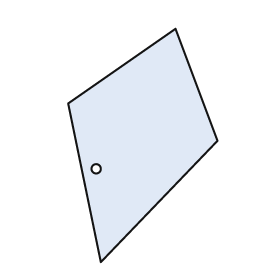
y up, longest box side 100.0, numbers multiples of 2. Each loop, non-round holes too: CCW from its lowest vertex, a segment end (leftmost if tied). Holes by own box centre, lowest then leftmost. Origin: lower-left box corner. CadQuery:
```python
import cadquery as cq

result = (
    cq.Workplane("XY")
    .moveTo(14.0, 0.0)
    .lineTo(64.0, 52.0)
    .lineTo(46.0, 100.0)
    .lineTo(0.0, 68.0)
    .close()
    .moveTo(12.0, 40.0)
    .circle(2.0)
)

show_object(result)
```